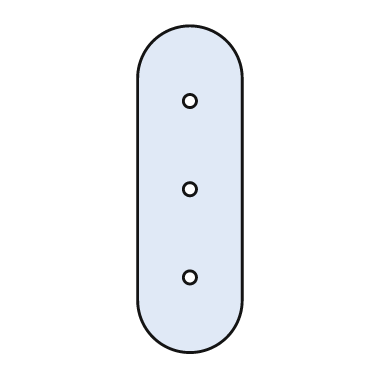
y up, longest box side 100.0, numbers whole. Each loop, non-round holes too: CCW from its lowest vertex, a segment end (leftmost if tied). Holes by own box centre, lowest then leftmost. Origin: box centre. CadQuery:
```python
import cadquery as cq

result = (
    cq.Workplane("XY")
    .moveTo(-16.0, -34.0)
    .threePointArc((0.0, -50.0), (16.0, -34.0))
    .lineTo(16.0, 34.0)
    .threePointArc((0.0, 50.0), (-16.0, 34.0))
    .close()
    .moveTo(0.0, -27.0)
    .circle(2.0)
    .moveTo(0.0, 0.0)
    .circle(2.0)
    .moveTo(0.0, 27.0)
    .circle(2.0)
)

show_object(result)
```